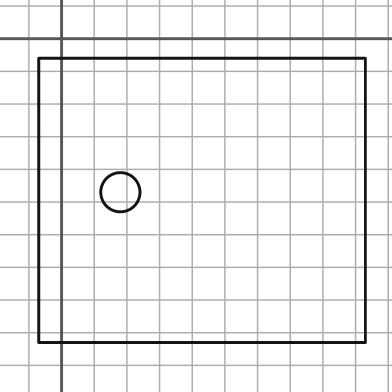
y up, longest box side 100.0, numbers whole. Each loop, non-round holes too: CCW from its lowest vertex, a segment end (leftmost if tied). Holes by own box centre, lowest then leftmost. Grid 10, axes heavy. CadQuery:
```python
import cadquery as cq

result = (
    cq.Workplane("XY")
    .moveTo(-7.0, -93.0)
    .lineTo(93.0, -93.0)
    .lineTo(93.0, -6.0)
    .lineTo(-7.0, -6.0)
    .close()
    .moveTo(18.0, -47.0)
    .circle(6.0)
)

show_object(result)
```